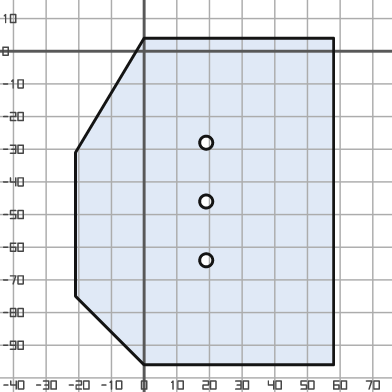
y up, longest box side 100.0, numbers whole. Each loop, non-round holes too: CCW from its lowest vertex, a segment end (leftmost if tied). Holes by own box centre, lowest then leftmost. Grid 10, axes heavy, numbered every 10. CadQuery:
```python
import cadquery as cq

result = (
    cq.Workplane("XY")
    .moveTo(0.0, -96.0)
    .lineTo(58.0, -96.0)
    .lineTo(58.0, 4.0)
    .lineTo(0.0, 4.0)
    .lineTo(-21.0, -31.0)
    .lineTo(-21.0, -75.0)
    .close()
    .moveTo(19.0, -64.0)
    .circle(2.0)
    .moveTo(19.0, -46.0)
    .circle(2.0)
    .moveTo(19.0, -28.0)
    .circle(2.0)
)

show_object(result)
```